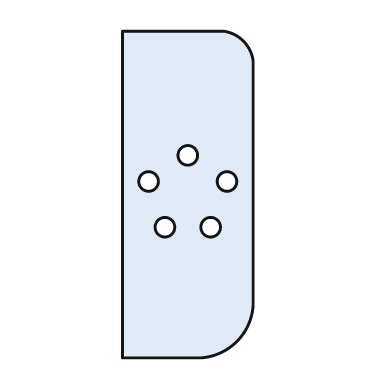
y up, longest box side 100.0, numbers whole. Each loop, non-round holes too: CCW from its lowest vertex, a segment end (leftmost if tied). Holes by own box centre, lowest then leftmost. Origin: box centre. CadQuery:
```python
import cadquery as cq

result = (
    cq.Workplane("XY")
    .moveTo(-20.0, -50.0)
    .lineTo(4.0, -50.0)
    .threePointArc((15.0, -45.0), (20.0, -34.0))
    .lineTo(20.0, 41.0)
    .threePointArc((17.0, 47.0), (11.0, 50.0))
    .lineTo(-20.0, 50.0)
    .close()
    .moveTo(-7.0, -10.0)
    .circle(3.0)
    .moveTo(7.0, -10.0)
    .circle(3.0)
    .moveTo(-12.0, 4.0)
    .circle(3.0)
    .moveTo(12.0, 4.0)
    .circle(3.0)
    .moveTo(0.0, 12.0)
    .circle(3.0)
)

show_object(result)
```